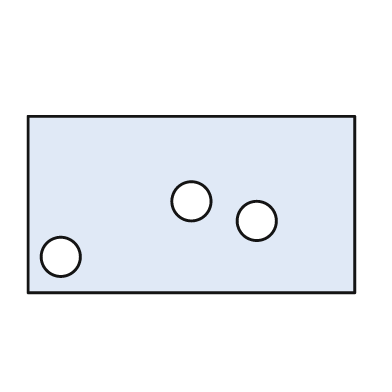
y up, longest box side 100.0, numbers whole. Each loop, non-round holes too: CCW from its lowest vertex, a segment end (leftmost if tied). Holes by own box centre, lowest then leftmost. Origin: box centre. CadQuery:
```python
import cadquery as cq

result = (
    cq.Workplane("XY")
    .moveTo(-50.0, -27.0)
    .lineTo(50.0, -27.0)
    .lineTo(50.0, 27.0)
    .lineTo(-50.0, 27.0)
    .close()
    .moveTo(-40.0, -16.0)
    .circle(6.0)
    .moveTo(20.0, -5.0)
    .circle(6.0)
    .moveTo(0.0, 1.0)
    .circle(6.0)
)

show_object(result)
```